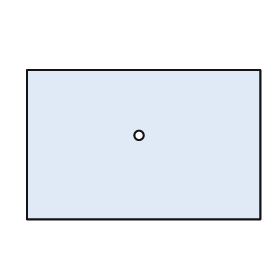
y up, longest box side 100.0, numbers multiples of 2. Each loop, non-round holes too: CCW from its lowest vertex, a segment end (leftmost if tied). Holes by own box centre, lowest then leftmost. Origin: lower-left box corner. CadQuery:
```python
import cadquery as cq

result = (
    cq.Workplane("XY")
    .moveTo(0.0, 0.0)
    .lineTo(100.0, 0.0)
    .lineTo(100.0, 64.0)
    .lineTo(0.0, 64.0)
    .close()
    .moveTo(48.0, 36.0)
    .circle(2.0)
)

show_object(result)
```